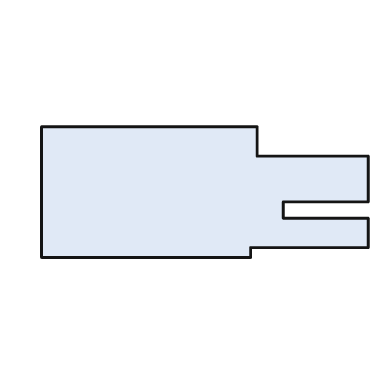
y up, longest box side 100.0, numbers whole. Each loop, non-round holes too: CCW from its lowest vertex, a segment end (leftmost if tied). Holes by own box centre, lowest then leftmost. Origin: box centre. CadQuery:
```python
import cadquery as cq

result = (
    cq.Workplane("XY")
    .moveTo(-50.0, -20.0)
    .lineTo(14.0, -20.0)
    .lineTo(14.0, -17.0)
    .lineTo(50.0, -17.0)
    .lineTo(50.0, -8.0)
    .lineTo(24.0, -8.0)
    .lineTo(24.0, -3.0)
    .lineTo(50.0, -3.0)
    .lineTo(50.0, 11.0)
    .lineTo(16.0, 11.0)
    .lineTo(16.0, 20.0)
    .lineTo(-50.0, 20.0)
    .close()
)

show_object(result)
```